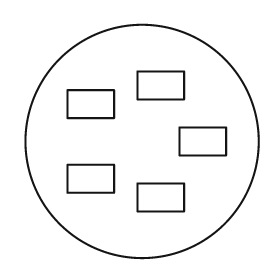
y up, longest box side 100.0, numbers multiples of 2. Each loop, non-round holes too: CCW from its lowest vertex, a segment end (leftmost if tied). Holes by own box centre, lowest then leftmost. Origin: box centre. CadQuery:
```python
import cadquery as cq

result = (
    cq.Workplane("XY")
    .moveTo(0.0, 0.0)
    .circle(50.0)
    .moveTo(-2.0, -30.0)
    .lineTo(18.0, -30.0)
    .lineTo(18.0, -18.0)
    .lineTo(-2.0, -18.0)
    .close()
    .moveTo(-32.0, -22.0)
    .lineTo(-12.0, -22.0)
    .lineTo(-12.0, -10.0)
    .lineTo(-32.0, -10.0)
    .close()
    .moveTo(16.0, -6.0)
    .lineTo(36.0, -6.0)
    .lineTo(36.0, 6.0)
    .lineTo(16.0, 6.0)
    .close()
    .moveTo(-32.0, 10.0)
    .lineTo(-12.0, 10.0)
    .lineTo(-12.0, 22.0)
    .lineTo(-32.0, 22.0)
    .close()
    .moveTo(-2.0, 18.0)
    .lineTo(18.0, 18.0)
    .lineTo(18.0, 30.0)
    .lineTo(-2.0, 30.0)
    .close()
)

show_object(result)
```